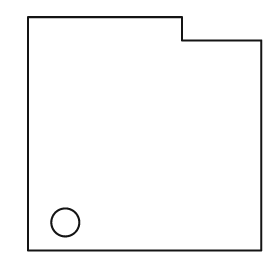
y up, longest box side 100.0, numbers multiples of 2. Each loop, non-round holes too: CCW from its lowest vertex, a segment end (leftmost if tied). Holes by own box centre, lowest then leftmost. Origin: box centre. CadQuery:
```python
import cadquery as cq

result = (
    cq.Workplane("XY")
    .moveTo(-50.0, -50.0)
    .lineTo(50.0, -50.0)
    .lineTo(50.0, 40.0)
    .lineTo(16.0, 40.0)
    .lineTo(16.0, 50.0)
    .lineTo(-50.0, 50.0)
    .close()
    .moveTo(-34.0, -38.0)
    .circle(6.0)
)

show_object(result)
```